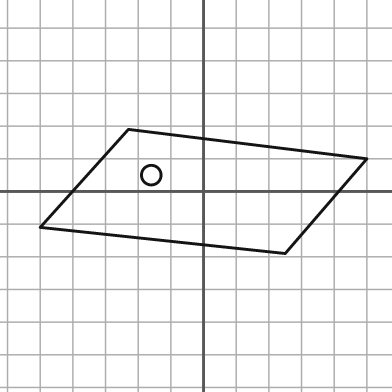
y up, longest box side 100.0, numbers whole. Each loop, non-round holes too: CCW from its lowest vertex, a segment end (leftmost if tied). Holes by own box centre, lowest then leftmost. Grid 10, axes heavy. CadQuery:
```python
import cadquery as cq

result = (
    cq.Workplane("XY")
    .moveTo(25.0, -19.0)
    .lineTo(50.0, 10.0)
    .lineTo(-23.0, 19.0)
    .lineTo(-50.0, -11.0)
    .close()
    .moveTo(-16.0, 5.0)
    .circle(3.0)
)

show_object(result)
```